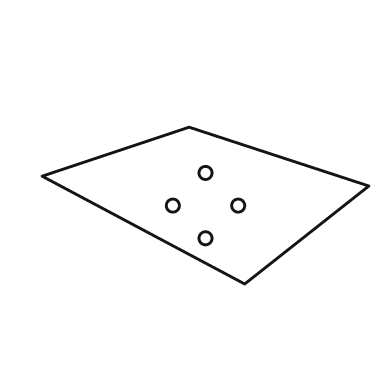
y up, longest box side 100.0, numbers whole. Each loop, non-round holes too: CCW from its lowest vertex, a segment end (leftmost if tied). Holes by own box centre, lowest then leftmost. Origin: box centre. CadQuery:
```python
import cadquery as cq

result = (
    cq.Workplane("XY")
    .moveTo(12.0, -24.0)
    .lineTo(50.0, 6.0)
    .lineTo(-5.0, 24.0)
    .lineTo(-50.0, 9.0)
    .close()
    .moveTo(0.0, -10.0)
    .circle(2.0)
    .moveTo(-10.0, 0.0)
    .circle(2.0)
    .moveTo(10.0, 0.0)
    .circle(2.0)
    .moveTo(0.0, 10.0)
    .circle(2.0)
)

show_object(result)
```